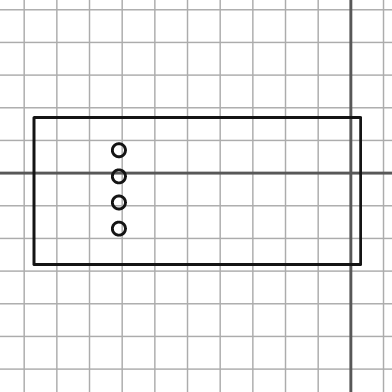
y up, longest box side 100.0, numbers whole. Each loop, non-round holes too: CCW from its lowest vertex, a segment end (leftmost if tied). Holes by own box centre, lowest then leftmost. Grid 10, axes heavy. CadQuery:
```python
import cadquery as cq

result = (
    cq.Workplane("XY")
    .moveTo(-97.0, -28.0)
    .lineTo(3.0, -28.0)
    .lineTo(3.0, 17.0)
    .lineTo(-97.0, 17.0)
    .close()
    .moveTo(-71.0, -17.0)
    .circle(2.0)
    .moveTo(-71.0, -9.0)
    .circle(2.0)
    .moveTo(-71.0, -1.0)
    .circle(2.0)
    .moveTo(-71.0, 7.0)
    .circle(2.0)
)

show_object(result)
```